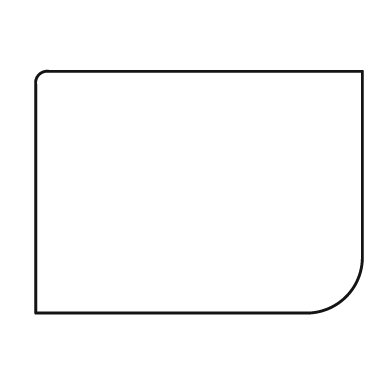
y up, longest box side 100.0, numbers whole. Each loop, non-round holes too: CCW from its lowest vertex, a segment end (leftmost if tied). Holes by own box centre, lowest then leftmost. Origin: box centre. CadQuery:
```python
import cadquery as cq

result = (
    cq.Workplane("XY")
    .moveTo(-50.0, -37.0)
    .lineTo(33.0, -37.0)
    .threePointArc((45.0, -32.0), (50.0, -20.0))
    .lineTo(50.0, 37.0)
    .lineTo(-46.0, 37.0)
    .threePointArc((-49.0, 36.0), (-50.0, 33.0))
    .close()
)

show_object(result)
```